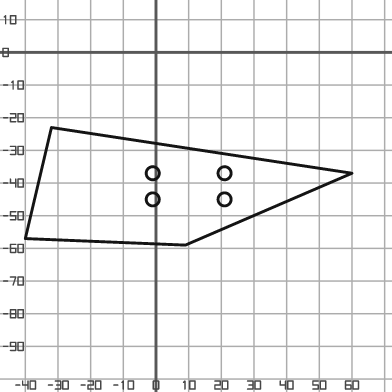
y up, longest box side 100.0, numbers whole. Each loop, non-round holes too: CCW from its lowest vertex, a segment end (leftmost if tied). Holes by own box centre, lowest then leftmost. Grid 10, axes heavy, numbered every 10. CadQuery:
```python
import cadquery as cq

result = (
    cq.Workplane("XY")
    .moveTo(9.0, -59.0)
    .lineTo(60.0, -37.0)
    .lineTo(-32.0, -23.0)
    .lineTo(-40.0, -57.0)
    .close()
    .moveTo(-1.0, -45.0)
    .circle(2.0)
    .moveTo(21.0, -45.0)
    .circle(2.0)
    .moveTo(-1.0, -37.0)
    .circle(2.0)
    .moveTo(21.0, -37.0)
    .circle(2.0)
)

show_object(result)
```